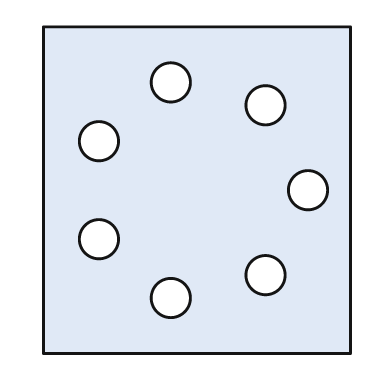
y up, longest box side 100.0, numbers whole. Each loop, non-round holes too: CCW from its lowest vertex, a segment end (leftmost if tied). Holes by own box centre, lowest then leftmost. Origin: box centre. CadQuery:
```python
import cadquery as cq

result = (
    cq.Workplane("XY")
    .moveTo(-47.0, -50.0)
    .lineTo(47.0, -50.0)
    .lineTo(47.0, 50.0)
    .lineTo(-47.0, 50.0)
    .close()
    .moveTo(-8.0, -33.0)
    .circle(6.0)
    .moveTo(21.0, -26.0)
    .circle(6.0)
    .moveTo(-30.0, -15.0)
    .circle(6.0)
    .moveTo(34.0, 0.0)
    .circle(6.0)
    .moveTo(-30.0, 15.0)
    .circle(6.0)
    .moveTo(21.0, 26.0)
    .circle(6.0)
    .moveTo(-8.0, 33.0)
    .circle(6.0)
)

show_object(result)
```